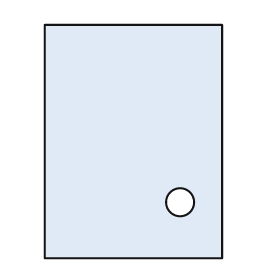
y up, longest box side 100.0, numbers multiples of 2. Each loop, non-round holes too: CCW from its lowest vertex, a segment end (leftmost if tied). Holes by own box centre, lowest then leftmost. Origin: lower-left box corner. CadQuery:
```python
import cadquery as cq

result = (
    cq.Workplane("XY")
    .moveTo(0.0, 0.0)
    .lineTo(76.0, 0.0)
    .lineTo(76.0, 100.0)
    .lineTo(0.0, 100.0)
    .close()
    .moveTo(58.0, 24.0)
    .circle(6.0)
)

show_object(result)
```